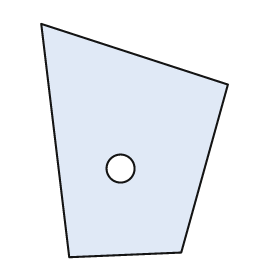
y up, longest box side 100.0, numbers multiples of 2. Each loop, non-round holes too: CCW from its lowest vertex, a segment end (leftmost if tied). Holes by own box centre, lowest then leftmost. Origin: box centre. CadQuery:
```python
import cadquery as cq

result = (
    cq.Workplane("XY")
    .moveTo(-28.0, -50.0)
    .lineTo(20.0, -48.0)
    .lineTo(40.0, 24.0)
    .lineTo(-40.0, 50.0)
    .close()
    .moveTo(-6.0, -12.0)
    .circle(6.0)
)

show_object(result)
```